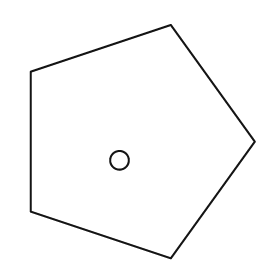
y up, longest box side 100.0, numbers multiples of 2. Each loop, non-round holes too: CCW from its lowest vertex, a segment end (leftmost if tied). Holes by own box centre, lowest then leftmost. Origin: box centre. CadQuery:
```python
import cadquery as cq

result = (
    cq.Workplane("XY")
    .moveTo(12.0, -50.0)
    .lineTo(48.0, 0.0)
    .lineTo(12.0, 50.0)
    .lineTo(-48.0, 30.0)
    .lineTo(-48.0, -30.0)
    .close()
    .moveTo(-10.0, -8.0)
    .circle(4.0)
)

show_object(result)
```